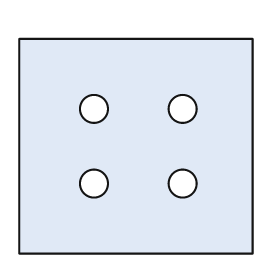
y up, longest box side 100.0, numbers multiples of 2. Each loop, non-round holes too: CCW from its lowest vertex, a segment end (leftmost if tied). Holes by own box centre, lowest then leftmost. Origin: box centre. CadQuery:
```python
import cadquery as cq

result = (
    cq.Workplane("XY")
    .moveTo(-50.0, -46.0)
    .lineTo(50.0, -46.0)
    .lineTo(50.0, 46.0)
    .lineTo(-50.0, 46.0)
    .close()
    .moveTo(-18.0, -16.0)
    .circle(6.0)
    .moveTo(20.0, -16.0)
    .circle(6.0)
    .moveTo(-18.0, 16.0)
    .circle(6.0)
    .moveTo(20.0, 16.0)
    .circle(6.0)
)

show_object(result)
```